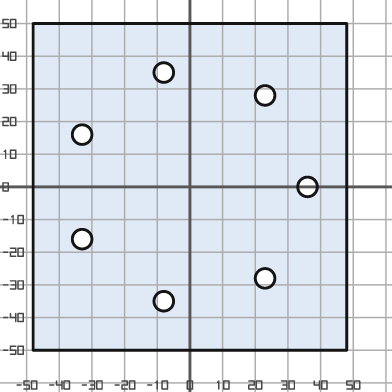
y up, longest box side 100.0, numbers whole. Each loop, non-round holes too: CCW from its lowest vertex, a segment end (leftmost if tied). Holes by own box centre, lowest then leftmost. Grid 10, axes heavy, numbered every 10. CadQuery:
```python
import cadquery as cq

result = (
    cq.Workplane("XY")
    .moveTo(-48.0, -50.0)
    .lineTo(48.0, -50.0)
    .lineTo(48.0, 50.0)
    .lineTo(-48.0, 50.0)
    .close()
    .moveTo(-8.0, -35.0)
    .circle(3.0)
    .moveTo(23.0, -28.0)
    .circle(3.0)
    .moveTo(-33.0, -16.0)
    .circle(3.0)
    .moveTo(36.0, 0.0)
    .circle(3.0)
    .moveTo(-33.0, 16.0)
    .circle(3.0)
    .moveTo(23.0, 28.0)
    .circle(3.0)
    .moveTo(-8.0, 35.0)
    .circle(3.0)
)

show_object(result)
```